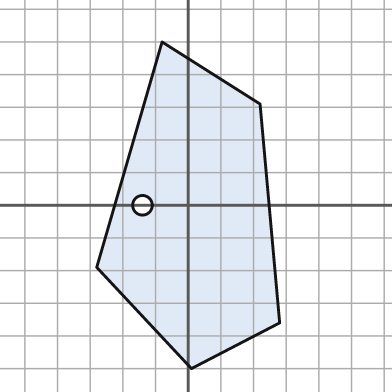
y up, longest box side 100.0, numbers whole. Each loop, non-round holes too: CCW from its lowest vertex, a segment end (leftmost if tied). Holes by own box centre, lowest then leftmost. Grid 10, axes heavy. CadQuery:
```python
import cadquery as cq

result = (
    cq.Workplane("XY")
    .moveTo(1.0, -50.0)
    .lineTo(28.0, -36.0)
    .lineTo(22.0, 31.0)
    .lineTo(-8.0, 50.0)
    .lineTo(-28.0, -19.0)
    .close()
    .moveTo(-14.0, 0.0)
    .circle(3.0)
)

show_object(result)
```